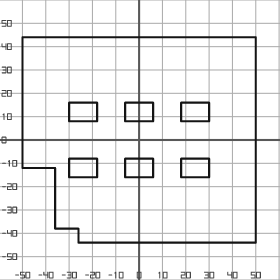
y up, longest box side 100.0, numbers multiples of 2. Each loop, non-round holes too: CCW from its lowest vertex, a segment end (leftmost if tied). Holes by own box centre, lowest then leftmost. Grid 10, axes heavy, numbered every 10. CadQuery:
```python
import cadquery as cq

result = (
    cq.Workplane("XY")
    .moveTo(-26.0, -44.0)
    .lineTo(50.0, -44.0)
    .lineTo(50.0, 44.0)
    .lineTo(-50.0, 44.0)
    .lineTo(-50.0, -12.0)
    .lineTo(-36.0, -12.0)
    .lineTo(-36.0, -38.0)
    .lineTo(-26.0, -38.0)
    .close()
    .moveTo(-30.0, -16.0)
    .lineTo(-18.0, -16.0)
    .lineTo(-18.0, -8.0)
    .lineTo(-30.0, -8.0)
    .close()
    .moveTo(-6.0, -16.0)
    .lineTo(6.0, -16.0)
    .lineTo(6.0, -8.0)
    .lineTo(-6.0, -8.0)
    .close()
    .moveTo(18.0, -16.0)
    .lineTo(30.0, -16.0)
    .lineTo(30.0, -8.0)
    .lineTo(18.0, -8.0)
    .close()
    .moveTo(-30.0, 8.0)
    .lineTo(-18.0, 8.0)
    .lineTo(-18.0, 16.0)
    .lineTo(-30.0, 16.0)
    .close()
    .moveTo(-6.0, 8.0)
    .lineTo(6.0, 8.0)
    .lineTo(6.0, 16.0)
    .lineTo(-6.0, 16.0)
    .close()
    .moveTo(18.0, 8.0)
    .lineTo(30.0, 8.0)
    .lineTo(30.0, 16.0)
    .lineTo(18.0, 16.0)
    .close()
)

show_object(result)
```